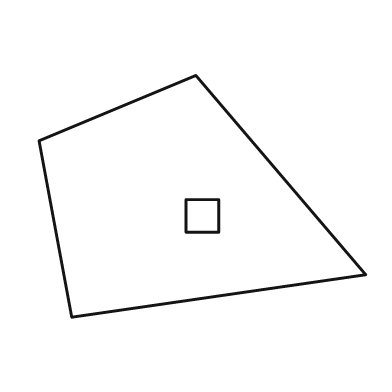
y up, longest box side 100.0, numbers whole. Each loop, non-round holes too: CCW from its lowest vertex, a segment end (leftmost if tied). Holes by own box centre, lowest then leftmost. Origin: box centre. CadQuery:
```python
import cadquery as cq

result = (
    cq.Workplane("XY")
    .moveTo(-40.0, -37.0)
    .lineTo(50.0, -24.0)
    .lineTo(-2.0, 37.0)
    .lineTo(-50.0, 17.0)
    .close()
    .moveTo(-5.0, -11.0)
    .lineTo(5.0, -11.0)
    .lineTo(5.0, -1.0)
    .lineTo(-5.0, -1.0)
    .close()
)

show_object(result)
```